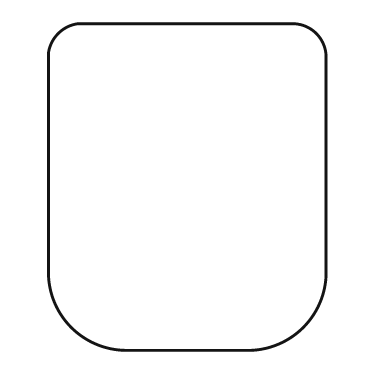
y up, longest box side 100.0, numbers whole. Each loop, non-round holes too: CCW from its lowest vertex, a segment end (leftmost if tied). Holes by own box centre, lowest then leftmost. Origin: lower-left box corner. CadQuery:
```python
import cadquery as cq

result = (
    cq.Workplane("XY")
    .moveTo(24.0, 0.0)
    .lineTo(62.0, 0.0)
    .threePointArc((78.0, 7.0), (85.0, 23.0))
    .lineTo(85.0, 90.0)
    .threePointArc((82.0, 97.0), (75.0, 100.0))
    .lineTo(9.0, 100.0)
    .threePointArc((3.0, 97.0), (0.0, 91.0))
    .lineTo(0.0, 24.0)
    .threePointArc((7.0, 7.0), (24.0, 0.0))
    .close()
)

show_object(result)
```